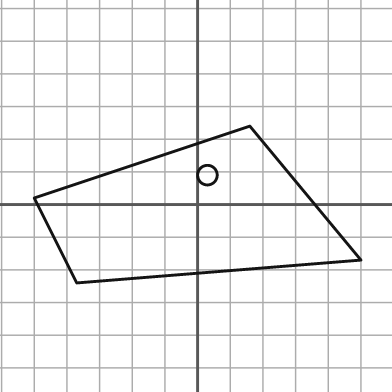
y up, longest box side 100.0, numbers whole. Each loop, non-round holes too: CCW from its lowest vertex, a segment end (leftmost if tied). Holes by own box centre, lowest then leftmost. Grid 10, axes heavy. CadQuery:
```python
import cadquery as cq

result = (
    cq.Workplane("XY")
    .moveTo(-37.0, -24.0)
    .lineTo(50.0, -17.0)
    .lineTo(16.0, 24.0)
    .lineTo(-50.0, 2.0)
    .close()
    .moveTo(3.0, 9.0)
    .circle(3.0)
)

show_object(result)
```